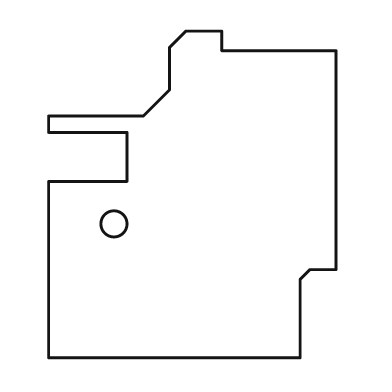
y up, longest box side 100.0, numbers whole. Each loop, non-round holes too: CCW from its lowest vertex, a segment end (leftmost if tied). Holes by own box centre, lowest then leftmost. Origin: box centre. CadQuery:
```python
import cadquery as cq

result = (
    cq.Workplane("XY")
    .moveTo(-44.0, -50.0)
    .lineTo(33.0, -50.0)
    .lineTo(33.0, -26.0)
    .lineTo(36.0, -23.0)
    .lineTo(44.0, -23.0)
    .lineTo(44.0, 44.0)
    .lineTo(9.0, 44.0)
    .lineTo(9.0, 50.0)
    .lineTo(-2.0, 50.0)
    .lineTo(-7.0, 45.0)
    .lineTo(-7.0, 32.0)
    .lineTo(-15.0, 24.0)
    .lineTo(-44.0, 24.0)
    .lineTo(-44.0, 19.0)
    .lineTo(-20.0, 19.0)
    .lineTo(-20.0, 4.0)
    .lineTo(-44.0, 4.0)
    .close()
    .moveTo(-24.0, -9.0)
    .circle(4.0)
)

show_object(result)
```